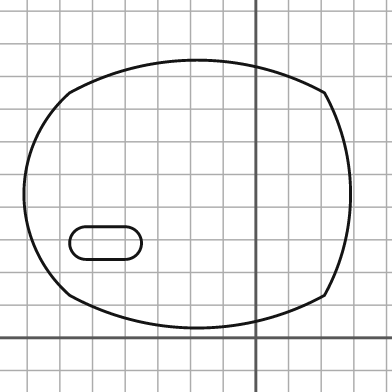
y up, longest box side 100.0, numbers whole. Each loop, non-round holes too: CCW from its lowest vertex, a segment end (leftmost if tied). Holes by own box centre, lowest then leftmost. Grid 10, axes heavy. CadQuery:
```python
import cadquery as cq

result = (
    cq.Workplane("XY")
    .moveTo(-57.0, 13.0)
    .threePointArc((-18.0, 3.0), (21.0, 13.0))
    .threePointArc((29.0, 44.0), (21.0, 75.0))
    .threePointArc((-18.0, 85.0), (-57.0, 75.0))
    .threePointArc((-71.0, 44.0), (-57.0, 13.0))
    .close()
    .moveTo(-52.0, 24.0)
    .lineTo(-40.0, 24.0)
    .threePointArc((-35.0, 29.0), (-40.0, 34.0))
    .lineTo(-52.0, 34.0)
    .threePointArc((-57.0, 29.0), (-52.0, 24.0))
    .close()
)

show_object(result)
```